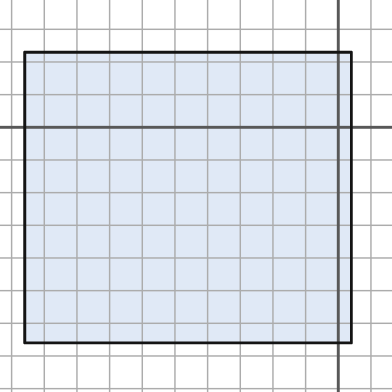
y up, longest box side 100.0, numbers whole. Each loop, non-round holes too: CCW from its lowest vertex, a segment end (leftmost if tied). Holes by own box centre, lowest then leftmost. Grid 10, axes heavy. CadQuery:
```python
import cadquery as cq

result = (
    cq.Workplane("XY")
    .moveTo(-96.0, -66.0)
    .lineTo(4.0, -66.0)
    .lineTo(4.0, 23.0)
    .lineTo(-96.0, 23.0)
    .close()
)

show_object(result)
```